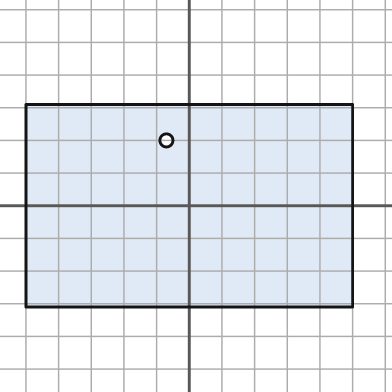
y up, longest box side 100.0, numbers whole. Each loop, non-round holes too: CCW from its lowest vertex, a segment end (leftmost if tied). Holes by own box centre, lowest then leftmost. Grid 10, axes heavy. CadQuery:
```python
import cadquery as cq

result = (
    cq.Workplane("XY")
    .moveTo(-50.0, -31.0)
    .lineTo(50.0, -31.0)
    .lineTo(50.0, 31.0)
    .lineTo(-50.0, 31.0)
    .close()
    .moveTo(-7.0, 20.0)
    .circle(2.0)
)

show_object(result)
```